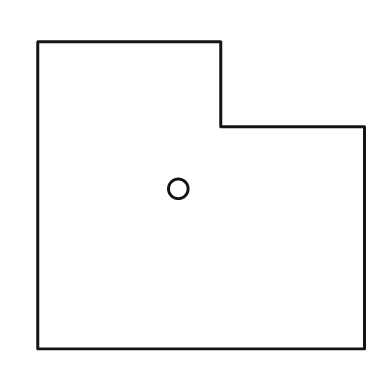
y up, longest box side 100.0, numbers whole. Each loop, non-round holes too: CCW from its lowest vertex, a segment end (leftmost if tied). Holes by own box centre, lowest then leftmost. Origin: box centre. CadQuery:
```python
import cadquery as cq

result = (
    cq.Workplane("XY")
    .moveTo(-50.0, -47.0)
    .lineTo(50.0, -47.0)
    .lineTo(50.0, 21.0)
    .lineTo(6.0, 21.0)
    .lineTo(6.0, 47.0)
    .lineTo(-50.0, 47.0)
    .close()
    .moveTo(-7.0, 2.0)
    .circle(3.0)
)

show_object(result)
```